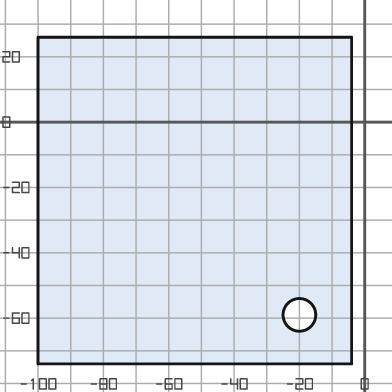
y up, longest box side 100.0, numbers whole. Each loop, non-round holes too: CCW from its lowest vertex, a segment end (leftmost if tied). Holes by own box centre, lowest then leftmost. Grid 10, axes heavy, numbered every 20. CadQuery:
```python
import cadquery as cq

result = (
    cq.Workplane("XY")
    .moveTo(-100.0, -74.0)
    .lineTo(-4.0, -74.0)
    .lineTo(-4.0, 26.0)
    .lineTo(-100.0, 26.0)
    .close()
    .moveTo(-20.0, -59.0)
    .circle(5.0)
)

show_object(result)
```